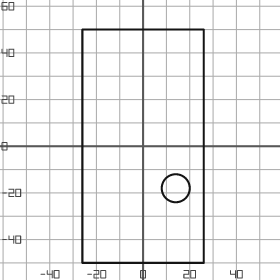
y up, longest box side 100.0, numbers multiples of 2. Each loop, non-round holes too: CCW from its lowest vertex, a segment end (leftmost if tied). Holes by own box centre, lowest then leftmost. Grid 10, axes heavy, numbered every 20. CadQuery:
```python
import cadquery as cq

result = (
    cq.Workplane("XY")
    .moveTo(-26.0, -50.0)
    .lineTo(26.0, -50.0)
    .lineTo(26.0, 50.0)
    .lineTo(-26.0, 50.0)
    .close()
    .moveTo(14.0, -18.0)
    .circle(6.0)
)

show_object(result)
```